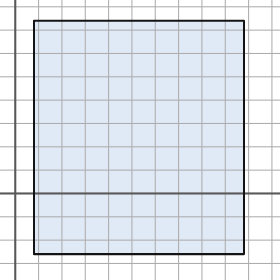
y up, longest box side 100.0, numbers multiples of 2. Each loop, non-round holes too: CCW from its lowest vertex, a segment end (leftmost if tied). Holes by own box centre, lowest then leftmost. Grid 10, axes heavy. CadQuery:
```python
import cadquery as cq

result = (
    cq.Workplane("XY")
    .moveTo(8.0, -26.0)
    .lineTo(98.0, -26.0)
    .lineTo(98.0, 74.0)
    .lineTo(8.0, 74.0)
    .close()
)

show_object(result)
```